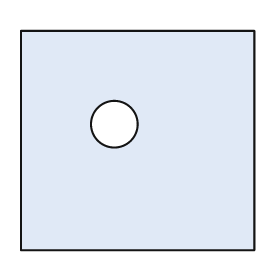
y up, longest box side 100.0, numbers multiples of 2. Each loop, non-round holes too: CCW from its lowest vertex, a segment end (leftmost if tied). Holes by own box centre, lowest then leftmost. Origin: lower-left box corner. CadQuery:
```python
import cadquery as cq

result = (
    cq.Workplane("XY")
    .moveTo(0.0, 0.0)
    .lineTo(100.0, 0.0)
    .lineTo(100.0, 94.0)
    .lineTo(0.0, 94.0)
    .close()
    .moveTo(40.0, 54.0)
    .circle(10.0)
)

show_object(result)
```